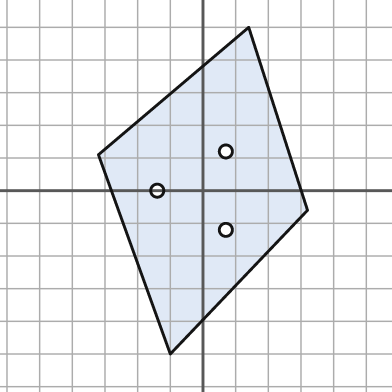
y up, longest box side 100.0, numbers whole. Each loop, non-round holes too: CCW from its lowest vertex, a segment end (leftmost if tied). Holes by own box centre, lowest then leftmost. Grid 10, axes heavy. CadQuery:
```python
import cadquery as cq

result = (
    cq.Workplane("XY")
    .moveTo(-10.0, -50.0)
    .lineTo(32.0, -6.0)
    .lineTo(14.0, 50.0)
    .lineTo(-32.0, 11.0)
    .close()
    .moveTo(7.0, -12.0)
    .circle(2.0)
    .moveTo(-14.0, 0.0)
    .circle(2.0)
    .moveTo(7.0, 12.0)
    .circle(2.0)
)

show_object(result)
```